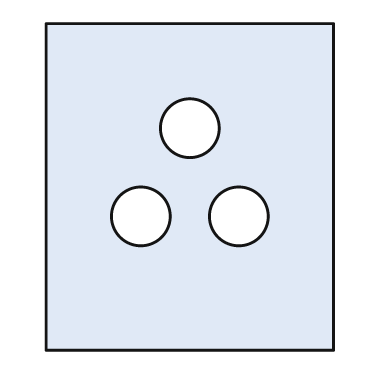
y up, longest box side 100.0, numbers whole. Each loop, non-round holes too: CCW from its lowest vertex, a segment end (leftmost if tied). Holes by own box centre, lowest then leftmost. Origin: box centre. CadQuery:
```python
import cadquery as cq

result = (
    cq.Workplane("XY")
    .moveTo(-44.0, -50.0)
    .lineTo(44.0, -50.0)
    .lineTo(44.0, 50.0)
    .lineTo(-44.0, 50.0)
    .close()
    .moveTo(-15.0, -9.0)
    .circle(9.0)
    .moveTo(15.0, -9.0)
    .circle(9.0)
    .moveTo(0.0, 18.0)
    .circle(9.0)
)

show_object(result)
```